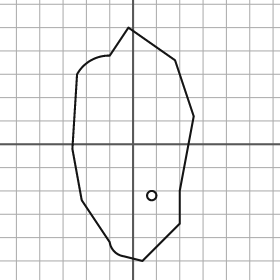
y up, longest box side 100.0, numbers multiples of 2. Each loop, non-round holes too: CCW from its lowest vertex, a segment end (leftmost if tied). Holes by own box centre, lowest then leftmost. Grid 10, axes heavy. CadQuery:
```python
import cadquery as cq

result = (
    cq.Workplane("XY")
    .moveTo(4.0, -50.0)
    .lineTo(20.0, -34.0)
    .lineTo(20.0, -20.0)
    .lineTo(26.0, 12.0)
    .lineTo(18.0, 36.0)
    .lineTo(-2.0, 50.0)
    .lineTo(-10.0, 38.0)
    .threePointArc((-18.0, 36.0), (-24.0, 30.0))
    .lineTo(-26.0, -2.0)
    .lineTo(-22.0, -24.0)
    .lineTo(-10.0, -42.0)
    .threePointArc((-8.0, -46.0), (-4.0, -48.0))
    .close()
    .moveTo(8.0, -22.0)
    .circle(2.0)
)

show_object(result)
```